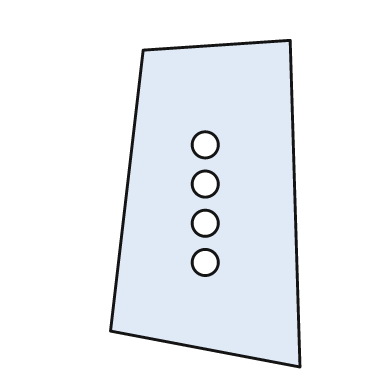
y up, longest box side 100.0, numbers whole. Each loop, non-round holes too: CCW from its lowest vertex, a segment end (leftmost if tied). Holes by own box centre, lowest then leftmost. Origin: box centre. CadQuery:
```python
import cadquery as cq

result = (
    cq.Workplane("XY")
    .moveTo(29.0, -50.0)
    .lineTo(26.0, 50.0)
    .lineTo(-19.0, 47.0)
    .lineTo(-29.0, -39.0)
    .close()
    .moveTo(0.0, -18.0)
    .circle(4.0)
    .moveTo(0.0, -6.0)
    .circle(4.0)
    .moveTo(0.0, 6.0)
    .circle(4.0)
    .moveTo(0.0, 18.0)
    .circle(4.0)
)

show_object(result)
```